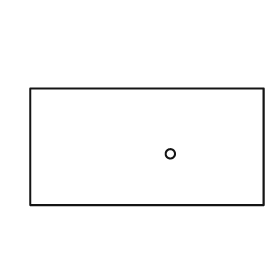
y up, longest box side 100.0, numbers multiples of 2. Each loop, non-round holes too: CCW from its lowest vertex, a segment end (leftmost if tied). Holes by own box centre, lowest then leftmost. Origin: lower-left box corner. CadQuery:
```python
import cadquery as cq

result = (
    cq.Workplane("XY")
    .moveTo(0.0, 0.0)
    .lineTo(100.0, 0.0)
    .lineTo(100.0, 50.0)
    .lineTo(0.0, 50.0)
    .close()
    .moveTo(60.0, 22.0)
    .circle(2.0)
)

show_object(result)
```